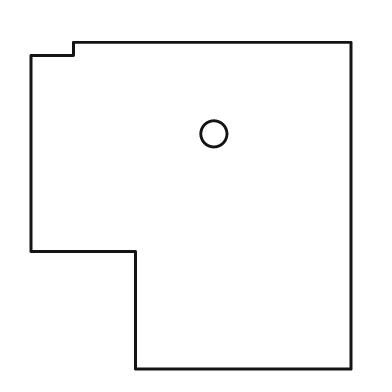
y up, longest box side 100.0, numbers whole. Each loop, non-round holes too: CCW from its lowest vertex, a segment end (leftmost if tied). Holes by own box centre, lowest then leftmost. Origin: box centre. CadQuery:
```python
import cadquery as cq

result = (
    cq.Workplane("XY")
    .moveTo(-17.0, -50.0)
    .lineTo(49.0, -50.0)
    .lineTo(49.0, 50.0)
    .lineTo(-36.0, 50.0)
    .lineTo(-36.0, 46.0)
    .lineTo(-49.0, 46.0)
    .lineTo(-49.0, -14.0)
    .lineTo(-17.0, -14.0)
    .close()
    .moveTo(7.0, 22.0)
    .circle(4.0)
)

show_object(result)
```